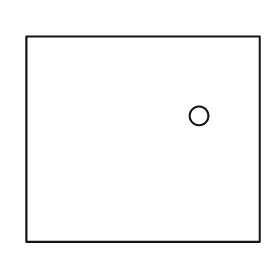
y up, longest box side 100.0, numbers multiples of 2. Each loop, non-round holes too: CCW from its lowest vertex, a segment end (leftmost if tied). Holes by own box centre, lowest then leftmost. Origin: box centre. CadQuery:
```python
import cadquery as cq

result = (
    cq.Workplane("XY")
    .moveTo(-50.0, -44.0)
    .lineTo(50.0, -44.0)
    .lineTo(50.0, 44.0)
    .lineTo(-50.0, 44.0)
    .close()
    .moveTo(24.0, 10.0)
    .circle(4.0)
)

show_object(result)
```